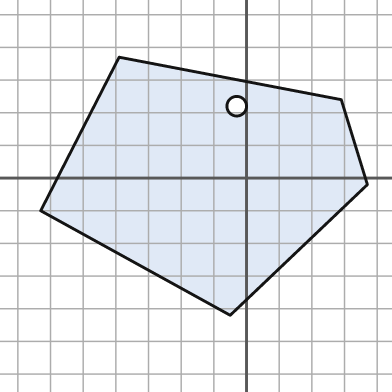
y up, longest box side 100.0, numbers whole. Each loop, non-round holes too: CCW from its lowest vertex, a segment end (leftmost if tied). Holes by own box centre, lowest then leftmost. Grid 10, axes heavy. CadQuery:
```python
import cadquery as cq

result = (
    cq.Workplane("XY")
    .moveTo(-5.0, -42.0)
    .lineTo(37.0, -2.0)
    .lineTo(29.0, 24.0)
    .lineTo(-39.0, 37.0)
    .lineTo(-63.0, -10.0)
    .close()
    .moveTo(-3.0, 22.0)
    .circle(3.0)
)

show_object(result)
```